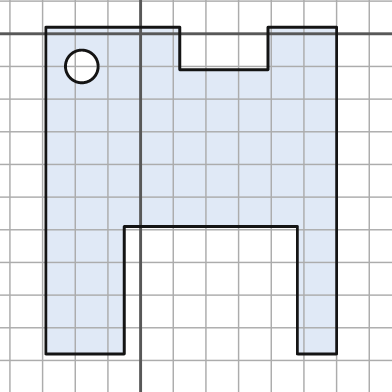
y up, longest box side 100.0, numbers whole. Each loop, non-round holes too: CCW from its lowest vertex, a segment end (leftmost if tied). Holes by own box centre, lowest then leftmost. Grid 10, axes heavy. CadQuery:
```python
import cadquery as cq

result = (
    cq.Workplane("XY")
    .moveTo(-29.0, -98.0)
    .lineTo(-5.0, -98.0)
    .lineTo(-5.0, -59.0)
    .lineTo(48.0, -59.0)
    .lineTo(48.0, -98.0)
    .lineTo(60.0, -98.0)
    .lineTo(60.0, 2.0)
    .lineTo(39.0, 2.0)
    .lineTo(39.0, -11.0)
    .lineTo(12.0, -11.0)
    .lineTo(12.0, 2.0)
    .lineTo(-29.0, 2.0)
    .close()
    .moveTo(-18.0, -10.0)
    .circle(5.0)
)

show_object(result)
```